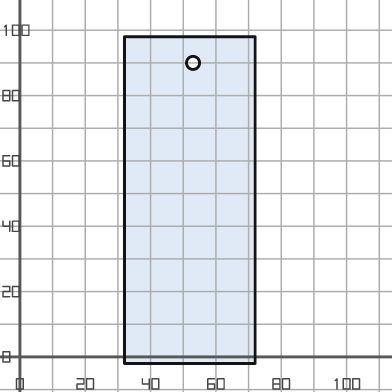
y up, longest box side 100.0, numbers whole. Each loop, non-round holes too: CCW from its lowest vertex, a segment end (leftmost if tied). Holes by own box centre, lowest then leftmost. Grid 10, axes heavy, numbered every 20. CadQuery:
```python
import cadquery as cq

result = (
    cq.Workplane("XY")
    .moveTo(32.0, -2.0)
    .lineTo(72.0, -2.0)
    .lineTo(72.0, 98.0)
    .lineTo(32.0, 98.0)
    .close()
    .moveTo(53.0, 90.0)
    .circle(2.0)
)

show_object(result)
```